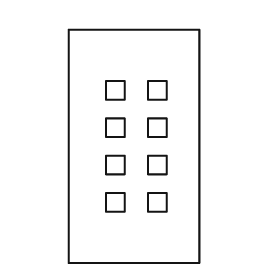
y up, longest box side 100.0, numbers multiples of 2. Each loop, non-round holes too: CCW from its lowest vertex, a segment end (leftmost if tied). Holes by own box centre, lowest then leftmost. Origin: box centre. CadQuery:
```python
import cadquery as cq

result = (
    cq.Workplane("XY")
    .moveTo(-28.0, -50.0)
    .lineTo(28.0, -50.0)
    .lineTo(28.0, 50.0)
    .lineTo(-28.0, 50.0)
    .close()
    .moveTo(-12.0, -28.0)
    .lineTo(-4.0, -28.0)
    .lineTo(-4.0, -20.0)
    .lineTo(-12.0, -20.0)
    .close()
    .moveTo(6.0, -28.0)
    .lineTo(14.0, -28.0)
    .lineTo(14.0, -20.0)
    .lineTo(6.0, -20.0)
    .close()
    .moveTo(-12.0, -12.0)
    .lineTo(-4.0, -12.0)
    .lineTo(-4.0, -4.0)
    .lineTo(-12.0, -4.0)
    .close()
    .moveTo(6.0, -12.0)
    .lineTo(14.0, -12.0)
    .lineTo(14.0, -4.0)
    .lineTo(6.0, -4.0)
    .close()
    .moveTo(-12.0, 4.0)
    .lineTo(-4.0, 4.0)
    .lineTo(-4.0, 12.0)
    .lineTo(-12.0, 12.0)
    .close()
    .moveTo(6.0, 4.0)
    .lineTo(14.0, 4.0)
    .lineTo(14.0, 12.0)
    .lineTo(6.0, 12.0)
    .close()
    .moveTo(-12.0, 20.0)
    .lineTo(-4.0, 20.0)
    .lineTo(-4.0, 28.0)
    .lineTo(-12.0, 28.0)
    .close()
    .moveTo(6.0, 20.0)
    .lineTo(14.0, 20.0)
    .lineTo(14.0, 28.0)
    .lineTo(6.0, 28.0)
    .close()
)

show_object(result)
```